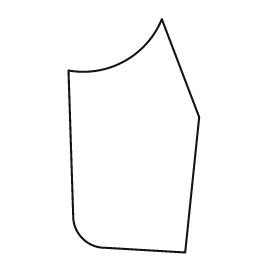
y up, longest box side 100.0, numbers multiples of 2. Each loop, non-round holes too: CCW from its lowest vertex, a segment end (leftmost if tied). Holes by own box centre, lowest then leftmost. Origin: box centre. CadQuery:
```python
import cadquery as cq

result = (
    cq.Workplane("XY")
    .moveTo(22.0, -50.0)
    .lineTo(28.0, 8.0)
    .lineTo(12.0, 50.0)
    .threePointArc((-4.0, 32.0), (-28.0, 28.0))
    .lineTo(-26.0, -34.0)
    .threePointArc((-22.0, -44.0), (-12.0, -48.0))
    .close()
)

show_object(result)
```